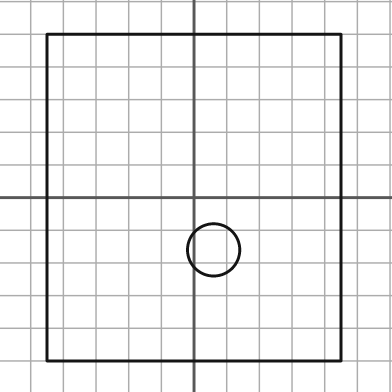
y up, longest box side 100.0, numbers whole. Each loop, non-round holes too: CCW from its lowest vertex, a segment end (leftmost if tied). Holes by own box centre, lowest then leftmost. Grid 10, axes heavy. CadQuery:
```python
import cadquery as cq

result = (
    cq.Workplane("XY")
    .moveTo(-45.0, -50.0)
    .lineTo(45.0, -50.0)
    .lineTo(45.0, 50.0)
    .lineTo(-45.0, 50.0)
    .close()
    .moveTo(6.0, -16.0)
    .circle(8.0)
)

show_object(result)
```